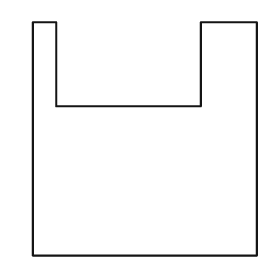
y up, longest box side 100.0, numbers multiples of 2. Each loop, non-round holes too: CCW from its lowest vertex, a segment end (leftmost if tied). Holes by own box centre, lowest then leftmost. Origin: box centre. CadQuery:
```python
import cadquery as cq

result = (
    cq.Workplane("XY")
    .moveTo(-48.0, -50.0)
    .lineTo(48.0, -50.0)
    .lineTo(48.0, 50.0)
    .lineTo(24.0, 50.0)
    .lineTo(24.0, 14.0)
    .lineTo(-38.0, 14.0)
    .lineTo(-38.0, 50.0)
    .lineTo(-48.0, 50.0)
    .close()
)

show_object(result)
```